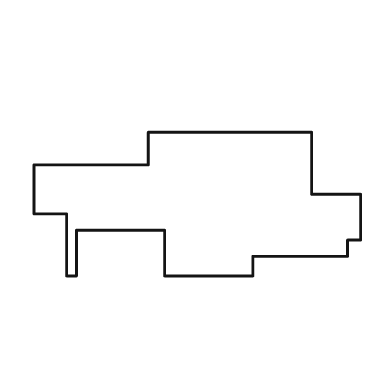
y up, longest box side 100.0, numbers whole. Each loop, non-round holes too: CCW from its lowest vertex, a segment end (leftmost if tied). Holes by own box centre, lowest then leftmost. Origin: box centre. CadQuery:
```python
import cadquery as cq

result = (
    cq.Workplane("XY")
    .moveTo(-40.0, -22.0)
    .lineTo(-37.0, -22.0)
    .lineTo(-37.0, -8.0)
    .lineTo(-10.0, -8.0)
    .lineTo(-10.0, -22.0)
    .lineTo(17.0, -22.0)
    .lineTo(17.0, -16.0)
    .lineTo(46.0, -16.0)
    .lineTo(46.0, -11.0)
    .lineTo(50.0, -11.0)
    .lineTo(50.0, 3.0)
    .lineTo(35.0, 3.0)
    .lineTo(35.0, 22.0)
    .lineTo(-15.0, 22.0)
    .lineTo(-15.0, 12.0)
    .lineTo(-50.0, 12.0)
    .lineTo(-50.0, -3.0)
    .lineTo(-40.0, -3.0)
    .close()
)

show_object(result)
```